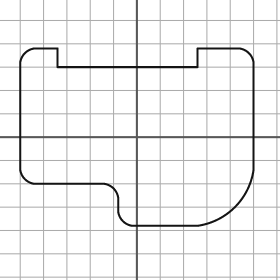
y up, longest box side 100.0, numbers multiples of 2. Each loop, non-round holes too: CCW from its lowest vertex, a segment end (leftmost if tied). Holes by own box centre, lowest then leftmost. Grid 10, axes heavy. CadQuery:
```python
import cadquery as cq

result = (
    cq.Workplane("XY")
    .moveTo(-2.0, -38.0)
    .lineTo(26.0, -38.0)
    .threePointArc((42.0, -30.0), (50.0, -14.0))
    .lineTo(50.0, 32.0)
    .threePointArc((48.0, 36.0), (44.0, 38.0))
    .lineTo(26.0, 38.0)
    .lineTo(26.0, 30.0)
    .lineTo(-34.0, 30.0)
    .lineTo(-34.0, 38.0)
    .lineTo(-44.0, 38.0)
    .threePointArc((-48.0, 36.0), (-50.0, 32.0))
    .lineTo(-50.0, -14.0)
    .threePointArc((-48.0, -18.0), (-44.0, -20.0))
    .lineTo(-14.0, -20.0)
    .threePointArc((-10.0, -22.0), (-8.0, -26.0))
    .lineTo(-8.0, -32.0)
    .threePointArc((-6.0, -36.0), (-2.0, -38.0))
    .close()
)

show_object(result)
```